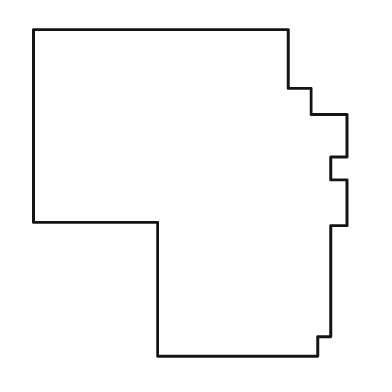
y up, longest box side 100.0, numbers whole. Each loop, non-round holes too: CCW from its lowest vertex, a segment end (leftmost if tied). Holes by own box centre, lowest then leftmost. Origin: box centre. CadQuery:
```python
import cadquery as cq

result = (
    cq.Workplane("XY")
    .moveTo(-10.0, -50.0)
    .lineTo(39.0, -50.0)
    .lineTo(39.0, -44.0)
    .lineTo(43.0, -44.0)
    .lineTo(43.0, -10.0)
    .lineTo(48.0, -10.0)
    .lineTo(48.0, 4.0)
    .lineTo(43.0, 4.0)
    .lineTo(43.0, 11.0)
    .lineTo(48.0, 11.0)
    .lineTo(48.0, 24.0)
    .lineTo(37.0, 24.0)
    .lineTo(37.0, 32.0)
    .lineTo(30.0, 32.0)
    .lineTo(30.0, 50.0)
    .lineTo(-48.0, 50.0)
    .lineTo(-48.0, -9.0)
    .lineTo(-10.0, -9.0)
    .close()
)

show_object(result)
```